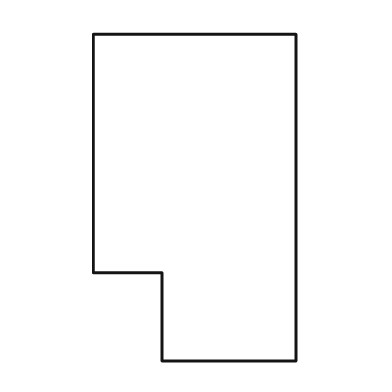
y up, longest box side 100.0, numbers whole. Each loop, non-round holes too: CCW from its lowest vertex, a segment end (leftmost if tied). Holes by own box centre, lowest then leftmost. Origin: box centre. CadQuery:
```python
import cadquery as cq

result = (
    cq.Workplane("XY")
    .moveTo(-10.0, -50.0)
    .lineTo(31.0, -50.0)
    .lineTo(31.0, 50.0)
    .lineTo(-31.0, 50.0)
    .lineTo(-31.0, -23.0)
    .lineTo(-10.0, -23.0)
    .close()
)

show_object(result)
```